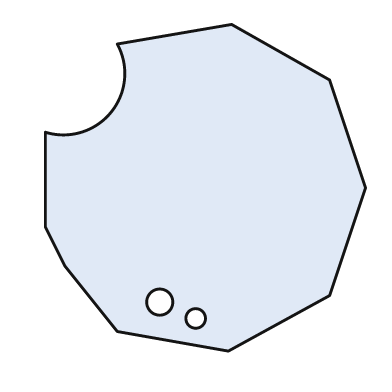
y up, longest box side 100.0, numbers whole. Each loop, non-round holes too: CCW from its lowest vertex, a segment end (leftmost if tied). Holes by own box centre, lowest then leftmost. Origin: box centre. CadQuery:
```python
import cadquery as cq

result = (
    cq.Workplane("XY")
    .moveTo(7.0, -50.0)
    .lineTo(38.0, -33.0)
    .lineTo(49.0, 0.0)
    .lineTo(38.0, 33.0)
    .lineTo(8.0, 50.0)
    .lineTo(-27.0, 44.0)
    .threePointArc((-29.0, 23.0), (-49.0, 17.0))
    .lineTo(-49.0, -12.0)
    .lineTo(-43.0, -24.0)
    .lineTo(-27.0, -44.0)
    .close()
    .moveTo(-3.0, -40.0)
    .circle(3.0)
    .moveTo(-14.0, -35.0)
    .circle(4.0)
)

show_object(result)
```